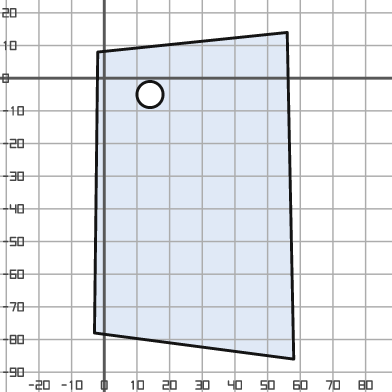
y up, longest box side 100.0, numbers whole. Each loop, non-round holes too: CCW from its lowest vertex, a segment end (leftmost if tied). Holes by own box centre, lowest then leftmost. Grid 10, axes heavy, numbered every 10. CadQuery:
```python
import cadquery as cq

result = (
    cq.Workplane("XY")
    .moveTo(58.0, -86.0)
    .lineTo(56.0, 14.0)
    .lineTo(-2.0, 8.0)
    .lineTo(-3.0, -78.0)
    .close()
    .moveTo(14.0, -5.0)
    .circle(4.0)
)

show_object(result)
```